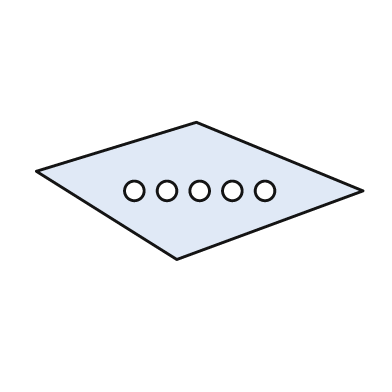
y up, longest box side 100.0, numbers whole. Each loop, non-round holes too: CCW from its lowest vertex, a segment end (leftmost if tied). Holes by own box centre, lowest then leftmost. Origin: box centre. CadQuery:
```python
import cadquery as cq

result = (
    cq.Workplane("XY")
    .moveTo(-7.0, -21.0)
    .lineTo(50.0, 0.0)
    .lineTo(-1.0, 21.0)
    .lineTo(-50.0, 6.0)
    .close()
    .moveTo(-20.0, 0.0)
    .circle(3.0)
    .moveTo(-10.0, 0.0)
    .circle(3.0)
    .moveTo(0.0, 0.0)
    .circle(3.0)
    .moveTo(10.0, 0.0)
    .circle(3.0)
    .moveTo(20.0, 0.0)
    .circle(3.0)
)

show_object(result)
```